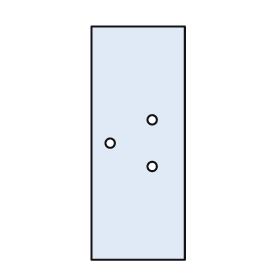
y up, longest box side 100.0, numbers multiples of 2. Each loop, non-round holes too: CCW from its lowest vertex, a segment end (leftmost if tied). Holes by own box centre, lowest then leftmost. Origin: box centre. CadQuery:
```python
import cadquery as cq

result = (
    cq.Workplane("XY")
    .moveTo(-20.0, -50.0)
    .lineTo(20.0, -50.0)
    .lineTo(20.0, 50.0)
    .lineTo(-20.0, 50.0)
    .close()
    .moveTo(6.0, -10.0)
    .circle(2.0)
    .moveTo(-12.0, 0.0)
    .circle(2.0)
    .moveTo(6.0, 10.0)
    .circle(2.0)
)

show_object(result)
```